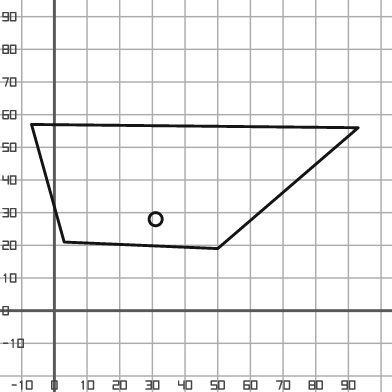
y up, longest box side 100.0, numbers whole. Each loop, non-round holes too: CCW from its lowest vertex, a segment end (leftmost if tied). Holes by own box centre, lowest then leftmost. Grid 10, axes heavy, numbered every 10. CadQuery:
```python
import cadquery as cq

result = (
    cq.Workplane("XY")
    .moveTo(50.0, 19.0)
    .lineTo(93.0, 56.0)
    .lineTo(-7.0, 57.0)
    .lineTo(3.0, 21.0)
    .close()
    .moveTo(31.0, 28.0)
    .circle(2.0)
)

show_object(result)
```